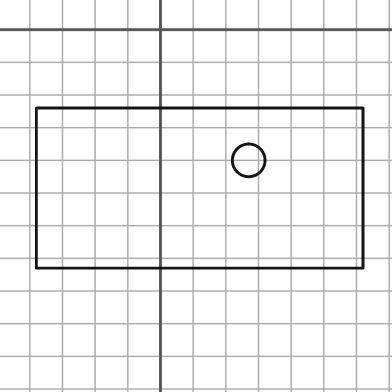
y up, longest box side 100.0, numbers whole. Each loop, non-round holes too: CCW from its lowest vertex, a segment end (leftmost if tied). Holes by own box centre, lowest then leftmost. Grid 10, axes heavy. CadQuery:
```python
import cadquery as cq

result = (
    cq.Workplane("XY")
    .moveTo(-38.0, -73.0)
    .lineTo(62.0, -73.0)
    .lineTo(62.0, -24.0)
    .lineTo(-38.0, -24.0)
    .close()
    .moveTo(27.0, -40.0)
    .circle(5.0)
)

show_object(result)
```